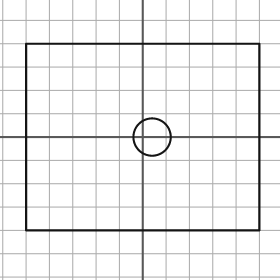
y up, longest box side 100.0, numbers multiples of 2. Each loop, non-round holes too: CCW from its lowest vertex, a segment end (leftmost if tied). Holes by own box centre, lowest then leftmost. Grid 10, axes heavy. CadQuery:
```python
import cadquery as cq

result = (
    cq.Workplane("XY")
    .moveTo(-50.0, -40.0)
    .lineTo(50.0, -40.0)
    .lineTo(50.0, 40.0)
    .lineTo(-50.0, 40.0)
    .close()
    .moveTo(4.0, 0.0)
    .circle(8.0)
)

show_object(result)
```